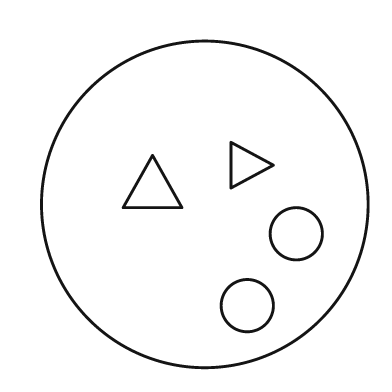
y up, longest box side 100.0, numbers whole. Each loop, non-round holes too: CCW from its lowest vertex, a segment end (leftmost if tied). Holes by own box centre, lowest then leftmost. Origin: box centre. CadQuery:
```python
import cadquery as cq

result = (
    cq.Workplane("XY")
    .moveTo(0.0, 0.0)
    .circle(50.0)
    .moveTo(13.0, -31.0)
    .circle(8.0)
    .moveTo(28.0, -9.0)
    .circle(8.0)
    .moveTo(-25.0, -1.0)
    .lineTo(-7.0, -1.0)
    .lineTo(-16.0, 15.0)
    .close()
    .moveTo(8.0, 5.0)
    .lineTo(21.0, 12.0)
    .lineTo(8.0, 19.0)
    .close()
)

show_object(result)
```